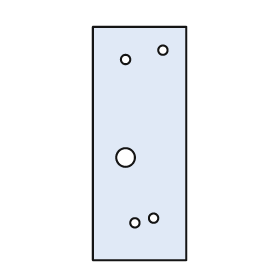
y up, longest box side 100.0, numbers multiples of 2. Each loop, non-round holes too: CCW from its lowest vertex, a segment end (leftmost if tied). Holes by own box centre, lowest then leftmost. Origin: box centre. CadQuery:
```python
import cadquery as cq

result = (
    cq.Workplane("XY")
    .moveTo(-20.0, -50.0)
    .lineTo(20.0, -50.0)
    .lineTo(20.0, 50.0)
    .lineTo(-20.0, 50.0)
    .close()
    .moveTo(-2.0, -34.0)
    .circle(2.0)
    .moveTo(6.0, -32.0)
    .circle(2.0)
    .moveTo(-6.0, -6.0)
    .circle(4.0)
    .moveTo(-6.0, 36.0)
    .circle(2.0)
    .moveTo(10.0, 40.0)
    .circle(2.0)
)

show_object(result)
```